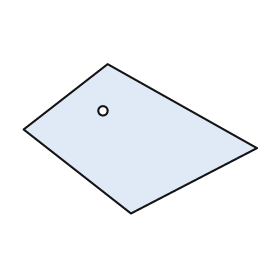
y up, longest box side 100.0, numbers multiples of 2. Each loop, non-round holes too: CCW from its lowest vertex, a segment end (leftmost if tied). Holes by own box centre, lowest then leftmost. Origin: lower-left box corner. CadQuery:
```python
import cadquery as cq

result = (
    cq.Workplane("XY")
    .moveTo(46.0, 0.0)
    .lineTo(100.0, 28.0)
    .lineTo(36.0, 64.0)
    .lineTo(0.0, 36.0)
    .close()
    .moveTo(34.0, 44.0)
    .circle(2.0)
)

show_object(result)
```